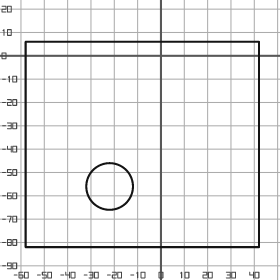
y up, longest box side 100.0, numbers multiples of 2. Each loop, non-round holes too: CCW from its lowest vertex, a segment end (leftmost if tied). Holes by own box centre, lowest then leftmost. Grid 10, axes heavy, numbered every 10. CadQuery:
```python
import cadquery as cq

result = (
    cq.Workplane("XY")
    .moveTo(-58.0, -82.0)
    .lineTo(42.0, -82.0)
    .lineTo(42.0, 6.0)
    .lineTo(-58.0, 6.0)
    .close()
    .moveTo(-22.0, -56.0)
    .circle(10.0)
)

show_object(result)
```